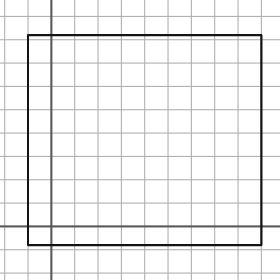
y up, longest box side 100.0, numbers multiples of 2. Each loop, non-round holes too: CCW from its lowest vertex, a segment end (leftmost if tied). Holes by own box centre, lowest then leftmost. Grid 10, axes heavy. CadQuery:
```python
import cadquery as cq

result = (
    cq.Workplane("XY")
    .moveTo(-10.0, -8.0)
    .lineTo(90.0, -8.0)
    .lineTo(90.0, 82.0)
    .lineTo(-10.0, 82.0)
    .close()
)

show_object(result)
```